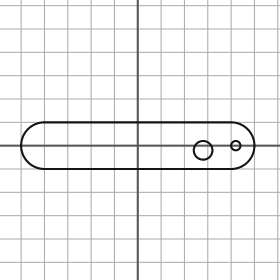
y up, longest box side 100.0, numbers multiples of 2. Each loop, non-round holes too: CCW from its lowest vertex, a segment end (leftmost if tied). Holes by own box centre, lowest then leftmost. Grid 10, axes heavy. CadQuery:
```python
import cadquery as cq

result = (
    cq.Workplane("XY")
    .moveTo(-40.0, -10.0)
    .lineTo(40.0, -10.0)
    .threePointArc((50.0, 0.0), (40.0, 10.0))
    .lineTo(-40.0, 10.0)
    .threePointArc((-50.0, 0.0), (-40.0, -10.0))
    .close()
    .moveTo(28.0, -2.0)
    .circle(4.0)
    .moveTo(42.0, 0.0)
    .circle(2.0)
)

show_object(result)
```